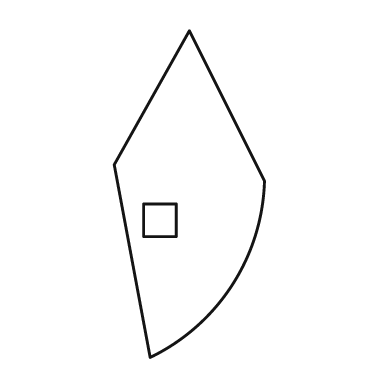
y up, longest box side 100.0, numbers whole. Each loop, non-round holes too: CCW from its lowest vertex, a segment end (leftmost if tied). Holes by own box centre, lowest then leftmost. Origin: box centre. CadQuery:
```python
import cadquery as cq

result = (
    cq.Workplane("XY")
    .moveTo(-12.0, -50.0)
    .threePointArc((13.0, -28.0), (23.0, 4.0))
    .lineTo(0.0, 50.0)
    .lineTo(-23.0, 9.0)
    .close()
    .moveTo(-14.0, -13.0)
    .lineTo(-4.0, -13.0)
    .lineTo(-4.0, -3.0)
    .lineTo(-14.0, -3.0)
    .close()
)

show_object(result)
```